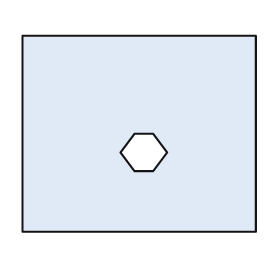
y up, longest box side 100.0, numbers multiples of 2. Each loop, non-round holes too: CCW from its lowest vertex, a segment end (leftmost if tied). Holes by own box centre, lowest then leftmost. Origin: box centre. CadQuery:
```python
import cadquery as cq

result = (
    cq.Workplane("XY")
    .moveTo(-50.0, -42.0)
    .lineTo(50.0, -42.0)
    .lineTo(50.0, 42.0)
    .lineTo(-50.0, 42.0)
    .close()
    .moveTo(-2.0, -16.0)
    .lineTo(6.0, -16.0)
    .lineTo(12.0, -8.0)
    .lineTo(6.0, 0.0)
    .lineTo(-2.0, 0.0)
    .lineTo(-8.0, -8.0)
    .close()
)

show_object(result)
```